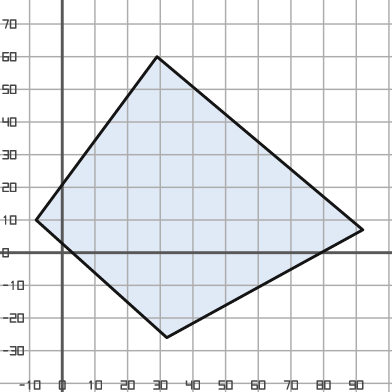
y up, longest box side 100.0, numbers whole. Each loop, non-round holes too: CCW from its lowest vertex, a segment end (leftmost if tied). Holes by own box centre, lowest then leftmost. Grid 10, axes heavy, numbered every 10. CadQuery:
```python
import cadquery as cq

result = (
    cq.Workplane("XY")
    .moveTo(32.0, -26.0)
    .lineTo(92.0, 7.0)
    .lineTo(29.0, 60.0)
    .lineTo(-8.0, 10.0)
    .close()
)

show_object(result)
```